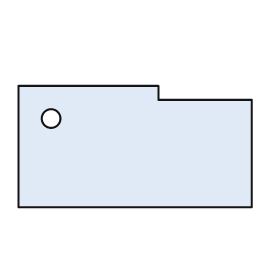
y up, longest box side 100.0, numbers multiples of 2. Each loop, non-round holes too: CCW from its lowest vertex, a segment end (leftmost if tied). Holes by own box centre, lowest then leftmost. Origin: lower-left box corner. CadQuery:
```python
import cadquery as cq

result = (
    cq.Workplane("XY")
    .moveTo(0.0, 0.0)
    .lineTo(100.0, 0.0)
    .lineTo(100.0, 46.0)
    .lineTo(60.0, 46.0)
    .lineTo(60.0, 52.0)
    .lineTo(0.0, 52.0)
    .close()
    .moveTo(14.0, 38.0)
    .circle(4.0)
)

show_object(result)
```